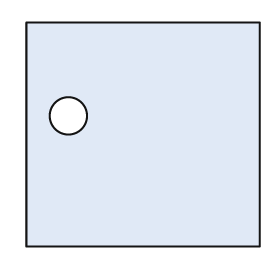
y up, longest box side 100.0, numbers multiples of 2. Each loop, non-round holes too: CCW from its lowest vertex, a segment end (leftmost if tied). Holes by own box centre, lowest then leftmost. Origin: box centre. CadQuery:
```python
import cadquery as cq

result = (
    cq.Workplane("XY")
    .moveTo(-50.0, -48.0)
    .lineTo(50.0, -48.0)
    .lineTo(50.0, 48.0)
    .lineTo(-50.0, 48.0)
    .close()
    .moveTo(-32.0, 8.0)
    .circle(8.0)
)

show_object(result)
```